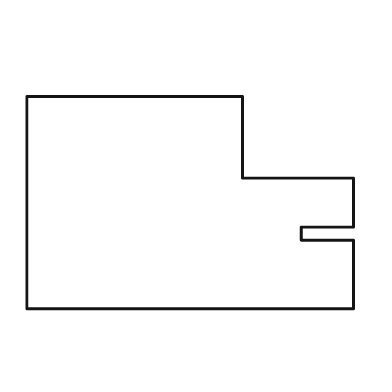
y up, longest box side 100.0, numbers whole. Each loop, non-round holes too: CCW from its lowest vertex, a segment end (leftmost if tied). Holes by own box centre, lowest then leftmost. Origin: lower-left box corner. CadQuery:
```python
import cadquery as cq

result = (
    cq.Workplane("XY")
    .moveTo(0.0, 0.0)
    .lineTo(100.0, 0.0)
    .lineTo(100.0, 21.0)
    .lineTo(84.0, 21.0)
    .lineTo(84.0, 25.0)
    .lineTo(100.0, 25.0)
    .lineTo(100.0, 40.0)
    .lineTo(66.0, 40.0)
    .lineTo(66.0, 65.0)
    .lineTo(0.0, 65.0)
    .close()
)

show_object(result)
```